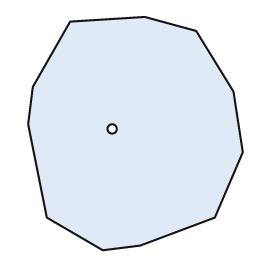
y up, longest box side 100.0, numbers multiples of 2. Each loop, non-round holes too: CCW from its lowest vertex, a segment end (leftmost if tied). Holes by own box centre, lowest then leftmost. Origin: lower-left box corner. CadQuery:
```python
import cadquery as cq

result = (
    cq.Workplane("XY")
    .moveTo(32.0, 0.0)
    .lineTo(48.0, 2.0)
    .lineTo(80.0, 14.0)
    .lineTo(92.0, 42.0)
    .lineTo(88.0, 68.0)
    .lineTo(72.0, 94.0)
    .lineTo(50.0, 100.0)
    .lineTo(18.0, 98.0)
    .lineTo(2.0, 70.0)
    .lineTo(0.0, 54.0)
    .lineTo(8.0, 14.0)
    .close()
    .moveTo(36.0, 52.0)
    .circle(2.0)
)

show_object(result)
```